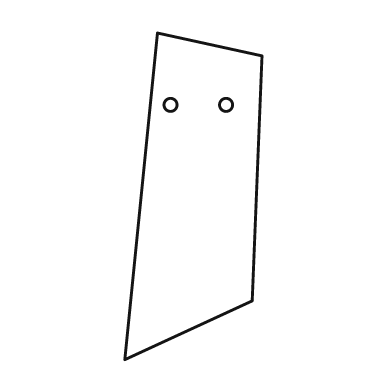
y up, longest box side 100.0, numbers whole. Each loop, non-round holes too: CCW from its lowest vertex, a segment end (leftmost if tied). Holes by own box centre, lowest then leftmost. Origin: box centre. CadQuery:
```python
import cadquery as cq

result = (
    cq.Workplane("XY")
    .moveTo(-21.0, -50.0)
    .lineTo(18.0, -32.0)
    .lineTo(21.0, 43.0)
    .lineTo(-11.0, 50.0)
    .close()
    .moveTo(-7.0, 28.0)
    .circle(2.0)
    .moveTo(10.0, 28.0)
    .circle(2.0)
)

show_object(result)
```